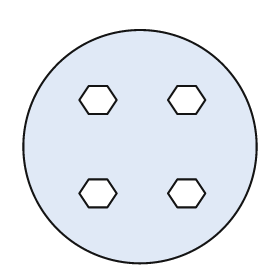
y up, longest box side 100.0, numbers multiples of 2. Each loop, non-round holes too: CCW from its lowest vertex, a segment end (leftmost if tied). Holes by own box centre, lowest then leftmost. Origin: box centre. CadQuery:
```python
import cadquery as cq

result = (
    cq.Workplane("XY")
    .moveTo(0.0, 0.0)
    .circle(50.0)
    .moveTo(-22.0, -26.0)
    .lineTo(-14.0, -26.0)
    .lineTo(-10.0, -20.0)
    .lineTo(-14.0, -14.0)
    .lineTo(-22.0, -14.0)
    .lineTo(-26.0, -20.0)
    .close()
    .moveTo(16.0, -26.0)
    .lineTo(24.0, -26.0)
    .lineTo(28.0, -20.0)
    .lineTo(24.0, -14.0)
    .lineTo(16.0, -14.0)
    .lineTo(12.0, -20.0)
    .close()
    .moveTo(-22.0, 14.0)
    .lineTo(-14.0, 14.0)
    .lineTo(-10.0, 20.0)
    .lineTo(-14.0, 26.0)
    .lineTo(-22.0, 26.0)
    .lineTo(-26.0, 20.0)
    .close()
    .moveTo(16.0, 14.0)
    .lineTo(24.0, 14.0)
    .lineTo(28.0, 20.0)
    .lineTo(24.0, 26.0)
    .lineTo(16.0, 26.0)
    .lineTo(12.0, 20.0)
    .close()
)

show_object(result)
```